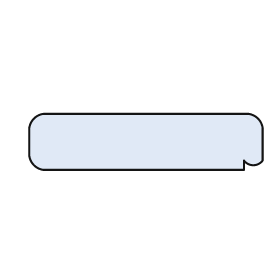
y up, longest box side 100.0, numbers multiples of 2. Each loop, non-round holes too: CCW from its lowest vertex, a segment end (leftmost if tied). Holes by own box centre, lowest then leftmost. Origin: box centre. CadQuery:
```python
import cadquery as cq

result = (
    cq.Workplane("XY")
    .moveTo(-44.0, -12.0)
    .lineTo(42.0, -12.0)
    .lineTo(42.0, -8.0)
    .threePointArc((46.0, -10.0), (50.0, -8.0))
    .lineTo(50.0, 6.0)
    .threePointArc((48.0, 10.0), (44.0, 12.0))
    .lineTo(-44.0, 12.0)
    .threePointArc((-48.0, 10.0), (-50.0, 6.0))
    .lineTo(-50.0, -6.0)
    .threePointArc((-48.0, -10.0), (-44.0, -12.0))
    .close()
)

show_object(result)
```